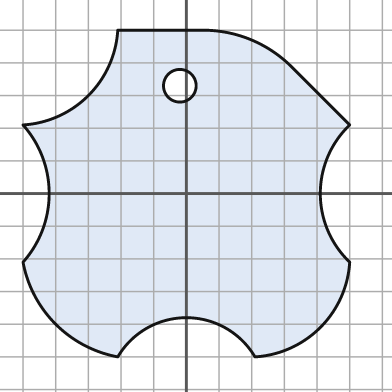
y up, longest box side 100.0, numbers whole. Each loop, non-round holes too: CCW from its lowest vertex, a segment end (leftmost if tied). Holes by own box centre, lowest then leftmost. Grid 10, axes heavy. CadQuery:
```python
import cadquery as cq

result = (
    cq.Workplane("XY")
    .moveTo(-21.0, -50.0)
    .threePointArc((0.0, -38.0), (21.0, -50.0))
    .threePointArc((41.0, -41.0), (50.0, -21.0))
    .threePointArc((41.0, 0.0), (50.0, 21.0))
    .lineTo(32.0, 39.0)
    .threePointArc((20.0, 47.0), (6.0, 50.0))
    .lineTo(-21.0, 50.0)
    .threePointArc((-30.0, 30.0), (-50.0, 21.0))
    .threePointArc((-42.0, 0.0), (-50.0, -21.0))
    .threePointArc((-40.0, -40.0), (-21.0, -50.0))
    .close()
    .moveTo(-2.0, 33.0)
    .circle(5.0)
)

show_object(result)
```